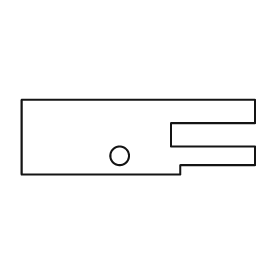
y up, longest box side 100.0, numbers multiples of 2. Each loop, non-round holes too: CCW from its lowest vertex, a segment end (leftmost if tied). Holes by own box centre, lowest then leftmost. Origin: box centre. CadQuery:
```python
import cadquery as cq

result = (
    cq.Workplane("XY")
    .moveTo(-50.0, -16.0)
    .lineTo(18.0, -16.0)
    .lineTo(18.0, -12.0)
    .lineTo(50.0, -12.0)
    .lineTo(50.0, -4.0)
    .lineTo(14.0, -4.0)
    .lineTo(14.0, 6.0)
    .lineTo(50.0, 6.0)
    .lineTo(50.0, 16.0)
    .lineTo(-50.0, 16.0)
    .close()
    .moveTo(-8.0, -8.0)
    .circle(4.0)
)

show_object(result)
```